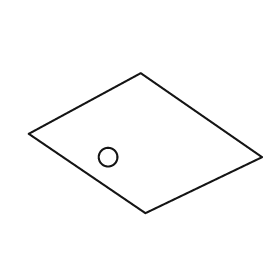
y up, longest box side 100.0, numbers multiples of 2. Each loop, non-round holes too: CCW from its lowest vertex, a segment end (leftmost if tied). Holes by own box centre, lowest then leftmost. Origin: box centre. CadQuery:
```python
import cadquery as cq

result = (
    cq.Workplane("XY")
    .moveTo(0.0, -30.0)
    .lineTo(50.0, -6.0)
    .lineTo(-2.0, 30.0)
    .lineTo(-50.0, 4.0)
    .close()
    .moveTo(-16.0, -6.0)
    .circle(4.0)
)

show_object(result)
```